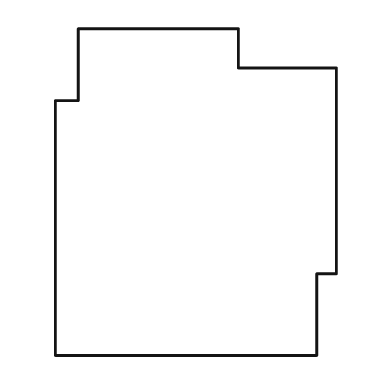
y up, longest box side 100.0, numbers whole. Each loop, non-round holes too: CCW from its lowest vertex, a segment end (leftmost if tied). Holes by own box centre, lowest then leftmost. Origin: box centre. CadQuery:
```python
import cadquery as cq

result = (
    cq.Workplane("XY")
    .moveTo(-43.0, -50.0)
    .lineTo(37.0, -50.0)
    .lineTo(37.0, -25.0)
    .lineTo(43.0, -25.0)
    .lineTo(43.0, 38.0)
    .lineTo(13.0, 38.0)
    .lineTo(13.0, 50.0)
    .lineTo(-36.0, 50.0)
    .lineTo(-36.0, 28.0)
    .lineTo(-43.0, 28.0)
    .close()
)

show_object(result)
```